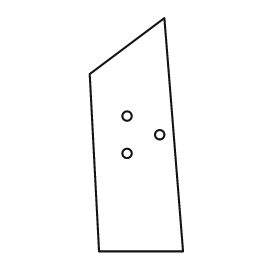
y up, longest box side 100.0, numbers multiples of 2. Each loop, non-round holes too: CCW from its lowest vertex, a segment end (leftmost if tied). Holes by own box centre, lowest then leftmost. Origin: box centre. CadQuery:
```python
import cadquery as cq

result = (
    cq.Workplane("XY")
    .moveTo(-16.0, -50.0)
    .lineTo(20.0, -50.0)
    .lineTo(12.0, 50.0)
    .lineTo(-20.0, 26.0)
    .close()
    .moveTo(-4.0, -8.0)
    .circle(2.0)
    .moveTo(10.0, 0.0)
    .circle(2.0)
    .moveTo(-4.0, 8.0)
    .circle(2.0)
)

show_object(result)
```